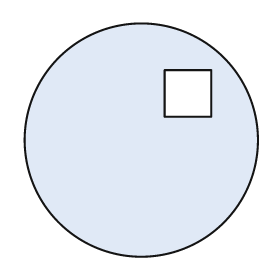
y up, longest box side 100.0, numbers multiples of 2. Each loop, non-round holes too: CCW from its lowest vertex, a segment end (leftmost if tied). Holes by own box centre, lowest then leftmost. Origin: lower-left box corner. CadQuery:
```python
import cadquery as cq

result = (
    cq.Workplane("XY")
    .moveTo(50.0, 50.0)
    .circle(50.0)
    .moveTo(60.0, 60.0)
    .lineTo(80.0, 60.0)
    .lineTo(80.0, 80.0)
    .lineTo(60.0, 80.0)
    .close()
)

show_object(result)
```